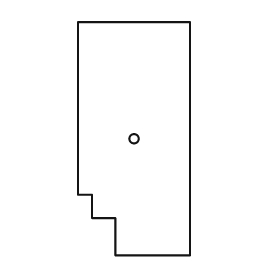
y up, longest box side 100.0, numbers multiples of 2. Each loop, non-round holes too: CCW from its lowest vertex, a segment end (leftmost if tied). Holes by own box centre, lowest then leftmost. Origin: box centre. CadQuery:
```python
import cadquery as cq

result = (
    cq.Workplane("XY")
    .moveTo(-8.0, -50.0)
    .lineTo(24.0, -50.0)
    .lineTo(24.0, 50.0)
    .lineTo(-24.0, 50.0)
    .lineTo(-24.0, -24.0)
    .lineTo(-18.0, -24.0)
    .lineTo(-18.0, -34.0)
    .lineTo(-8.0, -34.0)
    .close()
    .moveTo(0.0, 0.0)
    .circle(2.0)
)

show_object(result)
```